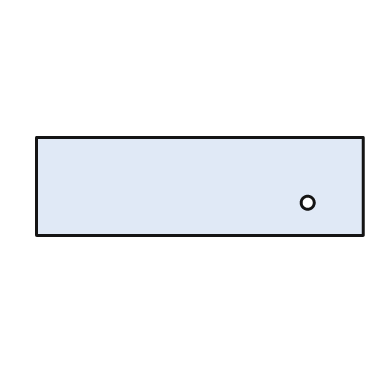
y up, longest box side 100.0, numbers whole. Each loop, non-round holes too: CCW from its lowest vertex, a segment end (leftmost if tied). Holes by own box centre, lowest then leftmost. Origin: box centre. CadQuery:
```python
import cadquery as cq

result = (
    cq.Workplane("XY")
    .moveTo(-50.0, -15.0)
    .lineTo(50.0, -15.0)
    .lineTo(50.0, 15.0)
    .lineTo(-50.0, 15.0)
    .close()
    .moveTo(33.0, -5.0)
    .circle(2.0)
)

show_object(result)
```